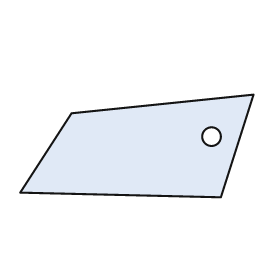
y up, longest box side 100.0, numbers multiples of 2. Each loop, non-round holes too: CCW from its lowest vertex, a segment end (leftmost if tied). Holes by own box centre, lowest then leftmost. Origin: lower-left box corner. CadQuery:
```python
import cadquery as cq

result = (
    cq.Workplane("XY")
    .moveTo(86.0, 0.0)
    .lineTo(100.0, 44.0)
    .lineTo(22.0, 36.0)
    .lineTo(0.0, 2.0)
    .close()
    .moveTo(82.0, 26.0)
    .circle(4.0)
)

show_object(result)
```